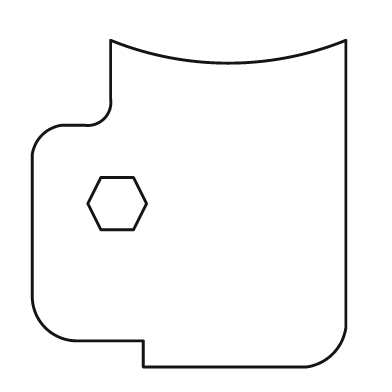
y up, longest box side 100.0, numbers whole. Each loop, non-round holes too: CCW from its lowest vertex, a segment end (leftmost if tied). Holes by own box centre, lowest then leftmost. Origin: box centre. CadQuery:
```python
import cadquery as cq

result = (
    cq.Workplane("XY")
    .moveTo(-14.0, -50.0)
    .lineTo(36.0, -50.0)
    .threePointArc((44.0, -46.0), (48.0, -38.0))
    .lineTo(48.0, 50.0)
    .threePointArc((12.0, 43.0), (-24.0, 50.0))
    .lineTo(-24.0, 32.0)
    .threePointArc((-26.0, 26.0), (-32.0, 24.0))
    .lineTo(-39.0, 24.0)
    .threePointArc((-45.0, 21.0), (-48.0, 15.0))
    .lineTo(-48.0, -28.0)
    .threePointArc((-44.0, -38.0), (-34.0, -42.0))
    .lineTo(-14.0, -42.0)
    .close()
    .moveTo(-27.0, -8.0)
    .lineTo(-17.0, -8.0)
    .lineTo(-13.0, 0.0)
    .lineTo(-17.0, 8.0)
    .lineTo(-27.0, 8.0)
    .lineTo(-31.0, 0.0)
    .close()
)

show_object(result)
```